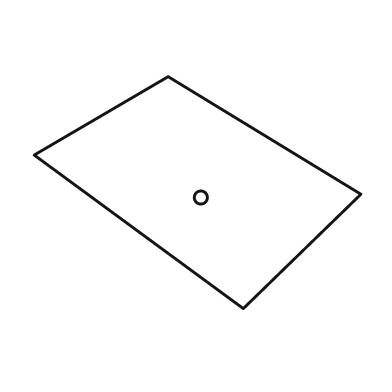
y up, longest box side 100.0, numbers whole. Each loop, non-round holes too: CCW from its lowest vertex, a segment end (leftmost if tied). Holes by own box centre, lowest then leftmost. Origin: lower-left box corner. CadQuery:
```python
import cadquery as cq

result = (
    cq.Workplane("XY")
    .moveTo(64.0, 0.0)
    .lineTo(100.0, 35.0)
    .lineTo(41.0, 71.0)
    .lineTo(0.0, 47.0)
    .close()
    .moveTo(51.0, 34.0)
    .circle(2.0)
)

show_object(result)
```